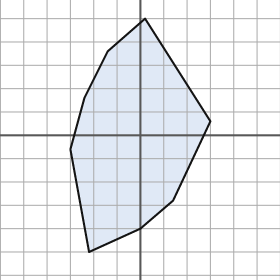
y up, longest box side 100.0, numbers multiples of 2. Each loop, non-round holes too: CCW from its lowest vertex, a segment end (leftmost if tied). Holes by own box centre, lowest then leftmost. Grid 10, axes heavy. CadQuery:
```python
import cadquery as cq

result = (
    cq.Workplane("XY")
    .moveTo(-22.0, -50.0)
    .lineTo(0.0, -40.0)
    .lineTo(14.0, -28.0)
    .lineTo(30.0, 6.0)
    .lineTo(2.0, 50.0)
    .lineTo(-14.0, 36.0)
    .lineTo(-24.0, 16.0)
    .lineTo(-30.0, -6.0)
    .close()
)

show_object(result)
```